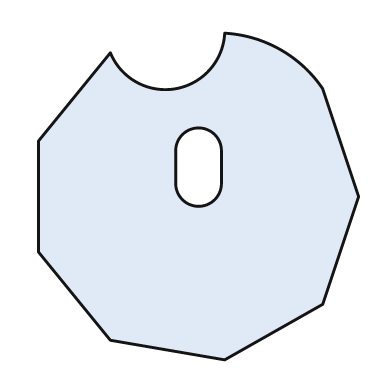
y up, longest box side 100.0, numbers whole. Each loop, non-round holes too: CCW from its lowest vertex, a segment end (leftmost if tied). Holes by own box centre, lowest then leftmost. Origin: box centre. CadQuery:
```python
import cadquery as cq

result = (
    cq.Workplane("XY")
    .moveTo(8.0, -50.0)
    .lineTo(38.0, -33.0)
    .lineTo(49.0, 0.0)
    .lineTo(38.0, 33.0)
    .threePointArc((25.0, 45.0), (8.0, 50.0))
    .threePointArc((-7.0, 33.0), (-27.0, 44.0))
    .lineTo(-49.0, 17.0)
    .lineTo(-49.0, -17.0)
    .lineTo(-27.0, -44.0)
    .close()
    .moveTo(-7.0, 4.0)
    .threePointArc((0.0, -3.0), (7.0, 4.0))
    .lineTo(7.0, 14.0)
    .threePointArc((0.0, 21.0), (-7.0, 14.0))
    .close()
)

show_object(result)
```